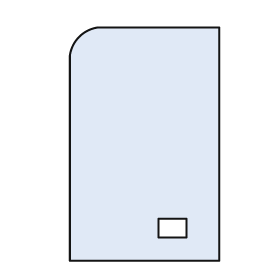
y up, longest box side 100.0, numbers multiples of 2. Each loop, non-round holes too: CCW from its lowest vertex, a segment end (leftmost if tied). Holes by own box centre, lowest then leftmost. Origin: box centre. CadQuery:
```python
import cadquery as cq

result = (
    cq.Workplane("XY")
    .moveTo(-32.0, -50.0)
    .lineTo(32.0, -50.0)
    .lineTo(32.0, 50.0)
    .lineTo(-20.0, 50.0)
    .threePointArc((-28.0, 46.0), (-32.0, 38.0))
    .close()
    .moveTo(6.0, -40.0)
    .lineTo(18.0, -40.0)
    .lineTo(18.0, -32.0)
    .lineTo(6.0, -32.0)
    .close()
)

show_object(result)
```